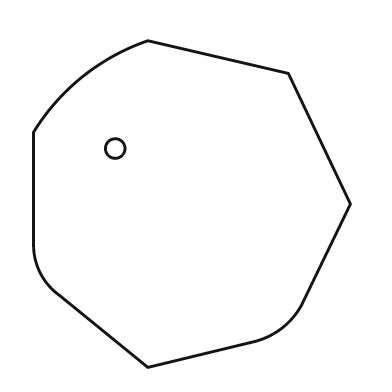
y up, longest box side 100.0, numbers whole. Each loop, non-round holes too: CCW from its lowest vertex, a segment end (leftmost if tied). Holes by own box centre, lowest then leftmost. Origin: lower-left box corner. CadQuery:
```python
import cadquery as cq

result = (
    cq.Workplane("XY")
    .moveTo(35.0, 0.0)
    .lineTo(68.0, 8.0)
    .threePointArc((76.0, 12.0), (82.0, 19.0))
    .lineTo(97.0, 50.0)
    .lineTo(78.0, 90.0)
    .lineTo(35.0, 100.0)
    .threePointArc((15.0, 89.0), (0.0, 72.0))
    .lineTo(0.0, 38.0)
    .threePointArc((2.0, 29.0), (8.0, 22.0))
    .close()
    .moveTo(25.0, 67.0)
    .circle(3.0)
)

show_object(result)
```